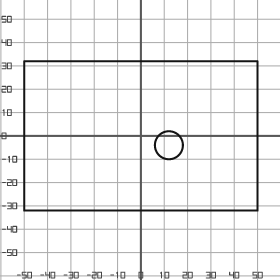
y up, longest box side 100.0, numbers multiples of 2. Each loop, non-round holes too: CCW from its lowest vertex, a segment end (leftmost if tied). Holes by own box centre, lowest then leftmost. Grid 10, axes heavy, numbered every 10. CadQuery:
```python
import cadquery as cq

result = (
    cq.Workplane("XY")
    .moveTo(-50.0, -32.0)
    .lineTo(50.0, -32.0)
    .lineTo(50.0, 32.0)
    .lineTo(-50.0, 32.0)
    .close()
    .moveTo(12.0, -4.0)
    .circle(6.0)
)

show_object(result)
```